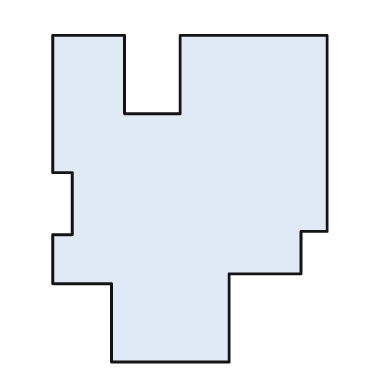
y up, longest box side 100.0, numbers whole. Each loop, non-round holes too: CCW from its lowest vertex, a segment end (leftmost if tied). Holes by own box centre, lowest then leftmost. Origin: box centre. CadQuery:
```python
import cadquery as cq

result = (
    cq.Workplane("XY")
    .moveTo(-24.0, -50.0)
    .lineTo(12.0, -50.0)
    .lineTo(12.0, -23.0)
    .lineTo(34.0, -23.0)
    .lineTo(34.0, -10.0)
    .lineTo(42.0, -10.0)
    .lineTo(42.0, 50.0)
    .lineTo(-3.0, 50.0)
    .lineTo(-3.0, 26.0)
    .lineTo(-20.0, 26.0)
    .lineTo(-20.0, 50.0)
    .lineTo(-42.0, 50.0)
    .lineTo(-42.0, 8.0)
    .lineTo(-36.0, 8.0)
    .lineTo(-36.0, -11.0)
    .lineTo(-42.0, -11.0)
    .lineTo(-42.0, -26.0)
    .lineTo(-24.0, -26.0)
    .close()
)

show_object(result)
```